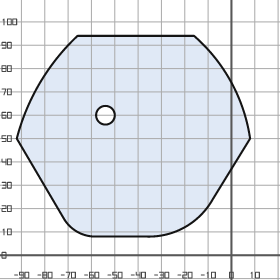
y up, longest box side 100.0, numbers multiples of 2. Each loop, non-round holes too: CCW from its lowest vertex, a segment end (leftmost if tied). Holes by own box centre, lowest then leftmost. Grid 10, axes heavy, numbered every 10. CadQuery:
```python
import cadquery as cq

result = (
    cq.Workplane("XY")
    .moveTo(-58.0, 8.0)
    .lineTo(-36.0, 8.0)
    .threePointArc((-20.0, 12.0), (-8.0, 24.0))
    .lineTo(8.0, 50.0)
    .threePointArc((0.0, 74.0), (-16.0, 94.0))
    .lineTo(-66.0, 94.0)
    .threePointArc((-82.0, 74.0), (-92.0, 50.0))
    .lineTo(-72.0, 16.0)
    .threePointArc((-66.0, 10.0), (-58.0, 8.0))
    .close()
    .moveTo(-54.0, 60.0)
    .circle(4.0)
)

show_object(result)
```